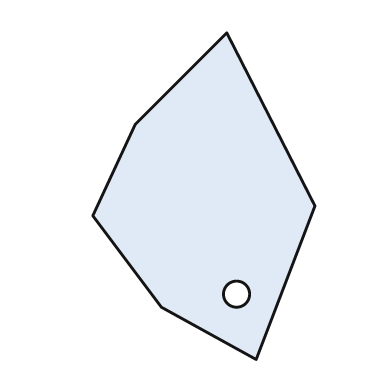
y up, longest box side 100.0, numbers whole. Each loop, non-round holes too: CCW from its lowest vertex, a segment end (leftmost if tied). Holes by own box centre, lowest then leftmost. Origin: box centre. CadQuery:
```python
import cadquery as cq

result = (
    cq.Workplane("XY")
    .moveTo(16.0, -50.0)
    .lineTo(34.0, -3.0)
    .lineTo(7.0, 50.0)
    .lineTo(-21.0, 22.0)
    .lineTo(-34.0, -6.0)
    .lineTo(-13.0, -34.0)
    .close()
    .moveTo(10.0, -30.0)
    .circle(4.0)
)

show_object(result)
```